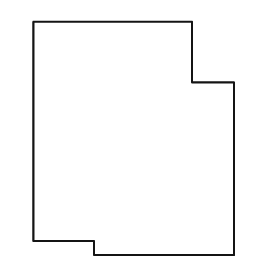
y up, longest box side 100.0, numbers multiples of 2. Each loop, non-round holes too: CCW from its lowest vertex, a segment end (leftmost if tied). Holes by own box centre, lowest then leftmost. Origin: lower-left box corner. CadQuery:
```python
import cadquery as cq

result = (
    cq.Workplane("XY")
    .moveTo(26.0, 0.0)
    .lineTo(86.0, 0.0)
    .lineTo(86.0, 74.0)
    .lineTo(68.0, 74.0)
    .lineTo(68.0, 100.0)
    .lineTo(0.0, 100.0)
    .lineTo(0.0, 6.0)
    .lineTo(26.0, 6.0)
    .close()
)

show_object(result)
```